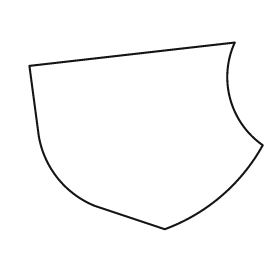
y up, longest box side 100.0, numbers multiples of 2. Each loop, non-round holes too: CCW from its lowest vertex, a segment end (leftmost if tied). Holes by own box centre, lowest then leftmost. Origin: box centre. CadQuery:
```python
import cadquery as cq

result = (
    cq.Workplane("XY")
    .moveTo(8.0, -40.0)
    .threePointArc((32.0, -26.0), (50.0, -4.0))
    .threePointArc((36.0, 16.0), (38.0, 40.0))
    .lineTo(-50.0, 30.0)
    .lineTo(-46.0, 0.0)
    .threePointArc((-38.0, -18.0), (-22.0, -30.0))
    .close()
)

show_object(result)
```